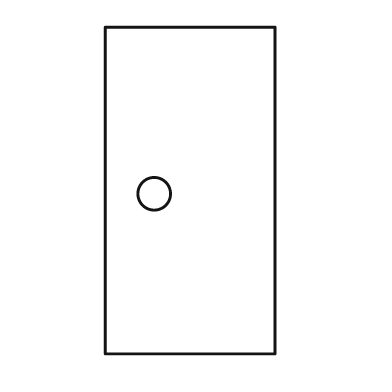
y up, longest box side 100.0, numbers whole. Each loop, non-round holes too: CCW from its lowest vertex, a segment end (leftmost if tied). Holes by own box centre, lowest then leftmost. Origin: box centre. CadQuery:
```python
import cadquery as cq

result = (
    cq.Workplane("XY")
    .moveTo(-26.0, -50.0)
    .lineTo(26.0, -50.0)
    .lineTo(26.0, 50.0)
    .lineTo(-26.0, 50.0)
    .close()
    .moveTo(-11.0, -1.0)
    .circle(5.0)
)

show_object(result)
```